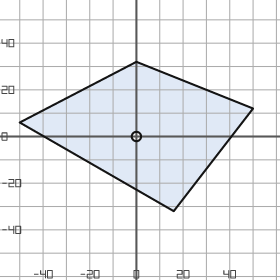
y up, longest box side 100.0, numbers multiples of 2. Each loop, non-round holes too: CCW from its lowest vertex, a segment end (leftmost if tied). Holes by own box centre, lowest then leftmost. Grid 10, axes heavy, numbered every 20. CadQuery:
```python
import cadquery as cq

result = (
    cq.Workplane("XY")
    .moveTo(16.0, -32.0)
    .lineTo(50.0, 12.0)
    .lineTo(0.0, 32.0)
    .lineTo(-50.0, 6.0)
    .close()
    .moveTo(0.0, 0.0)
    .circle(2.0)
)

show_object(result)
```